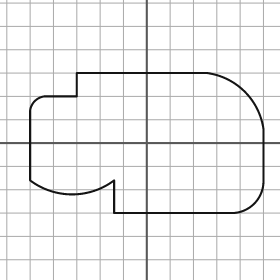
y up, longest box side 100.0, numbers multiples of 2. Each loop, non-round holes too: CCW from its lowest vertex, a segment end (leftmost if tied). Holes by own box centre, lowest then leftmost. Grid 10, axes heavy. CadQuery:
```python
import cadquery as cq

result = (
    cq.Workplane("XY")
    .moveTo(-14.0, -30.0)
    .lineTo(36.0, -30.0)
    .threePointArc((46.0, -26.0), (50.0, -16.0))
    .lineTo(50.0, 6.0)
    .threePointArc((42.0, 22.0), (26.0, 30.0))
    .lineTo(-30.0, 30.0)
    .lineTo(-30.0, 20.0)
    .lineTo(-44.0, 20.0)
    .threePointArc((-48.0, 18.0), (-50.0, 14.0))
    .lineTo(-50.0, -16.0)
    .threePointArc((-32.0, -22.0), (-14.0, -16.0))
    .close()
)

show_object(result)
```